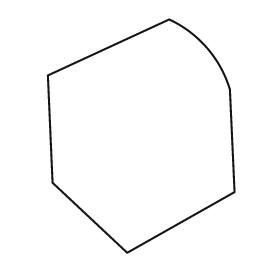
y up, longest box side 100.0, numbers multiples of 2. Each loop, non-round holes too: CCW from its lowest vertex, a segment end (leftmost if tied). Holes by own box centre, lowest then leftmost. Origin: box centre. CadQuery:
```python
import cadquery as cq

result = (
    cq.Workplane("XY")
    .moveTo(-6.0, -50.0)
    .lineTo(40.0, -24.0)
    .lineTo(38.0, 20.0)
    .threePointArc((28.0, 38.0), (12.0, 50.0))
    .lineTo(-40.0, 26.0)
    .lineTo(-38.0, -20.0)
    .close()
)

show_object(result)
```